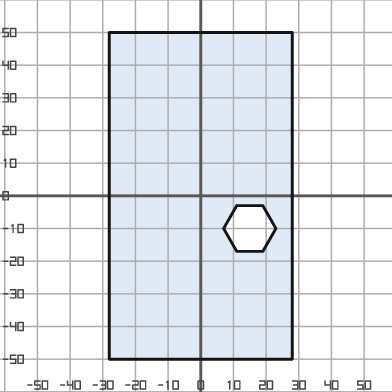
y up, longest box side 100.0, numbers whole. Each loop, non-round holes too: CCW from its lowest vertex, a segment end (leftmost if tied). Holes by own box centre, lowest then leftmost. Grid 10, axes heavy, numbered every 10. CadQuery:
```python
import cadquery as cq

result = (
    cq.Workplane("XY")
    .moveTo(-28.0, -50.0)
    .lineTo(28.0, -50.0)
    .lineTo(28.0, 50.0)
    .lineTo(-28.0, 50.0)
    .close()
    .moveTo(11.0, -17.0)
    .lineTo(19.0, -17.0)
    .lineTo(23.0, -10.0)
    .lineTo(19.0, -3.0)
    .lineTo(11.0, -3.0)
    .lineTo(7.0, -10.0)
    .close()
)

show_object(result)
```